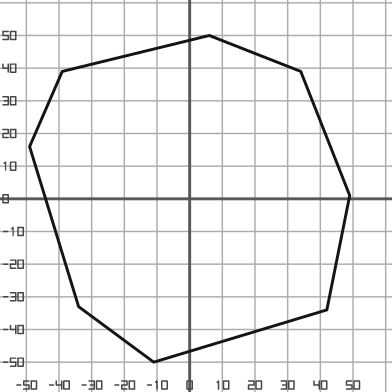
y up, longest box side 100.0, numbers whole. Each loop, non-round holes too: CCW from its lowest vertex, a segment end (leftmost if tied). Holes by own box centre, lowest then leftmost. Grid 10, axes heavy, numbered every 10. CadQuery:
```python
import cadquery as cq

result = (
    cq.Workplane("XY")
    .moveTo(-11.0, -50.0)
    .lineTo(42.0, -34.0)
    .lineTo(49.0, 1.0)
    .lineTo(34.0, 39.0)
    .lineTo(6.0, 50.0)
    .lineTo(-39.0, 39.0)
    .lineTo(-49.0, 16.0)
    .lineTo(-34.0, -33.0)
    .close()
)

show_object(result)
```